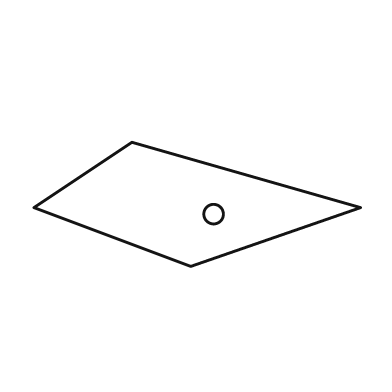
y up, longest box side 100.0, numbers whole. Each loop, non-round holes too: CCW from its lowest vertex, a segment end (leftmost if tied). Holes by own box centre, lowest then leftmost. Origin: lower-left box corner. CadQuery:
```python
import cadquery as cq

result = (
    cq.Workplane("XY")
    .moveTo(48.0, 0.0)
    .lineTo(100.0, 18.0)
    .lineTo(30.0, 38.0)
    .lineTo(0.0, 18.0)
    .close()
    .moveTo(55.0, 16.0)
    .circle(3.0)
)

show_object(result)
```